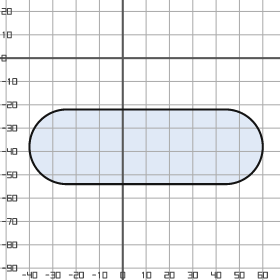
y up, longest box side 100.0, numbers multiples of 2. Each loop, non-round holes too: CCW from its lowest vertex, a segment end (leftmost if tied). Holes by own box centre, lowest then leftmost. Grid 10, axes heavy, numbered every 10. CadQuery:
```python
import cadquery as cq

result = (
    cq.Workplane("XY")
    .moveTo(-24.0, -54.0)
    .lineTo(44.0, -54.0)
    .threePointArc((60.0, -38.0), (44.0, -22.0))
    .lineTo(-24.0, -22.0)
    .threePointArc((-40.0, -38.0), (-24.0, -54.0))
    .close()
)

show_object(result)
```